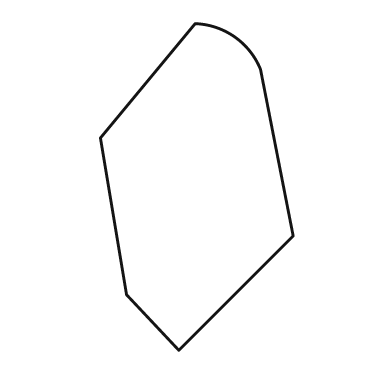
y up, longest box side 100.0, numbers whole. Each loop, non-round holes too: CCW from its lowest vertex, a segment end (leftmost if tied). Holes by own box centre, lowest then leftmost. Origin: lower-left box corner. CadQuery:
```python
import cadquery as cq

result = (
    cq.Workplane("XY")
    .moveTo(24.0, 0.0)
    .lineTo(59.0, 35.0)
    .lineTo(49.0, 86.0)
    .threePointArc((41.0, 96.0), (29.0, 100.0))
    .lineTo(0.0, 65.0)
    .lineTo(8.0, 17.0)
    .close()
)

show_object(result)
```